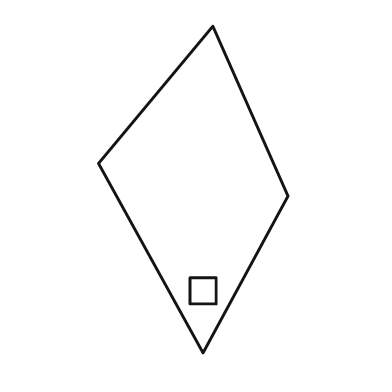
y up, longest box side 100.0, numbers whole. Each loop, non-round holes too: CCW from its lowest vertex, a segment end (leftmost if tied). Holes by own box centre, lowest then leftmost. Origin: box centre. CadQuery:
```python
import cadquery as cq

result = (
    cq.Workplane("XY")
    .moveTo(3.0, -50.0)
    .lineTo(29.0, -2.0)
    .lineTo(6.0, 50.0)
    .lineTo(-29.0, 8.0)
    .close()
    .moveTo(-1.0, -35.0)
    .lineTo(7.0, -35.0)
    .lineTo(7.0, -27.0)
    .lineTo(-1.0, -27.0)
    .close()
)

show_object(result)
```